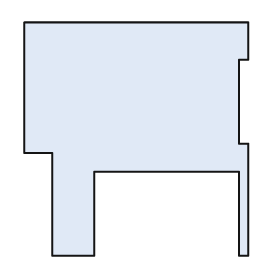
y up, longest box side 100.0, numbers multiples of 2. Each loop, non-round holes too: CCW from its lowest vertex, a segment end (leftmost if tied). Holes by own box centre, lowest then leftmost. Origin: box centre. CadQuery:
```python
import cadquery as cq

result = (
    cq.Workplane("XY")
    .moveTo(-36.0, -50.0)
    .lineTo(-18.0, -50.0)
    .lineTo(-18.0, -14.0)
    .lineTo(44.0, -14.0)
    .lineTo(44.0, -50.0)
    .lineTo(48.0, -50.0)
    .lineTo(48.0, -2.0)
    .lineTo(44.0, -2.0)
    .lineTo(44.0, 34.0)
    .lineTo(48.0, 34.0)
    .lineTo(48.0, 50.0)
    .lineTo(-48.0, 50.0)
    .lineTo(-48.0, -6.0)
    .lineTo(-36.0, -6.0)
    .close()
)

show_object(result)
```